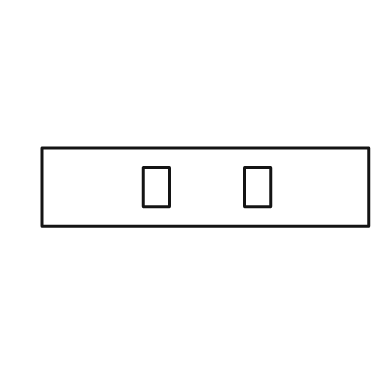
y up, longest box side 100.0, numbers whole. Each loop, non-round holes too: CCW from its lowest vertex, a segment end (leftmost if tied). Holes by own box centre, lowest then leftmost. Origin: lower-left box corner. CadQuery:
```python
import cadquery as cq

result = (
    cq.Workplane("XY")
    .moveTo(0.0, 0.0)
    .lineTo(100.0, 0.0)
    .lineTo(100.0, 24.0)
    .lineTo(0.0, 24.0)
    .close()
    .moveTo(31.0, 6.0)
    .lineTo(39.0, 6.0)
    .lineTo(39.0, 18.0)
    .lineTo(31.0, 18.0)
    .close()
    .moveTo(62.0, 6.0)
    .lineTo(70.0, 6.0)
    .lineTo(70.0, 18.0)
    .lineTo(62.0, 18.0)
    .close()
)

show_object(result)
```